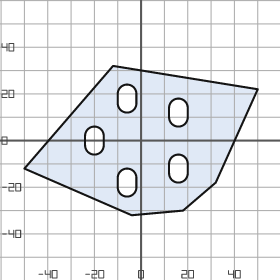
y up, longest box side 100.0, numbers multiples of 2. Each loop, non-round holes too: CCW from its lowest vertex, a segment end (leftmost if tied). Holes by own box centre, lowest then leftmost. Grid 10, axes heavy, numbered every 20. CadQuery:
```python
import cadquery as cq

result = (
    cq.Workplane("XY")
    .moveTo(-4.0, -32.0)
    .lineTo(18.0, -30.0)
    .lineTo(32.0, -18.0)
    .lineTo(50.0, 22.0)
    .lineTo(-12.0, 32.0)
    .lineTo(-50.0, -12.0)
    .close()
    .moveTo(-10.0, -20.0)
    .threePointArc((-6.0, -24.0), (-2.0, -20.0))
    .lineTo(-2.0, -16.0)
    .threePointArc((-6.0, -12.0), (-10.0, -16.0))
    .close()
    .moveTo(12.0, -14.0)
    .threePointArc((16.0, -18.0), (20.0, -14.0))
    .lineTo(20.0, -10.0)
    .threePointArc((16.0, -6.0), (12.0, -10.0))
    .close()
    .moveTo(-24.0, -2.0)
    .threePointArc((-20.0, -6.0), (-16.0, -2.0))
    .lineTo(-16.0, 2.0)
    .threePointArc((-20.0, 6.0), (-24.0, 2.0))
    .close()
    .moveTo(12.0, 10.0)
    .threePointArc((16.0, 6.0), (20.0, 10.0))
    .lineTo(20.0, 14.0)
    .threePointArc((16.0, 18.0), (12.0, 14.0))
    .close()
    .moveTo(-10.0, 16.0)
    .threePointArc((-6.0, 12.0), (-2.0, 16.0))
    .lineTo(-2.0, 20.0)
    .threePointArc((-6.0, 24.0), (-10.0, 20.0))
    .close()
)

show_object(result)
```